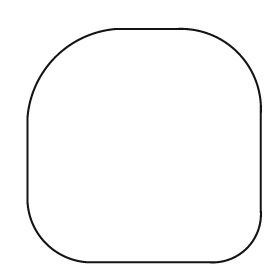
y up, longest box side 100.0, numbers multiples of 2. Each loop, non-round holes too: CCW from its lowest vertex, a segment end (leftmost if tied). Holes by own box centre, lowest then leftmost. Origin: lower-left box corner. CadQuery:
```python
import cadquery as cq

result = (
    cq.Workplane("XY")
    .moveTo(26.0, 0.0)
    .lineTo(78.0, 0.0)
    .threePointArc((94.0, 6.0), (100.0, 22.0))
    .lineTo(100.0, 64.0)
    .threePointArc((90.0, 90.0), (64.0, 100.0))
    .lineTo(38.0, 100.0)
    .threePointArc((12.0, 88.0), (0.0, 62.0))
    .lineTo(0.0, 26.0)
    .threePointArc((8.0, 8.0), (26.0, 0.0))
    .close()
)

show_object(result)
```